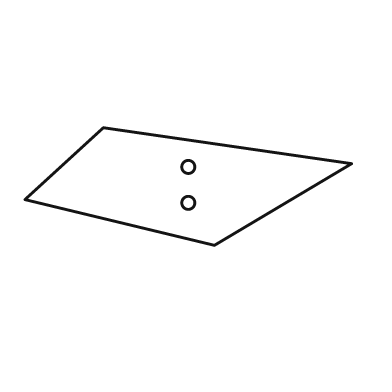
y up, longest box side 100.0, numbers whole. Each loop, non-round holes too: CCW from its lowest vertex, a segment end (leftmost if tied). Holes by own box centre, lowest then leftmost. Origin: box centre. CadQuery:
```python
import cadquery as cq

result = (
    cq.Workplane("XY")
    .moveTo(8.0, -18.0)
    .lineTo(50.0, 7.0)
    .lineTo(-26.0, 18.0)
    .lineTo(-50.0, -4.0)
    .close()
    .moveTo(0.0, -5.0)
    .circle(2.0)
    .moveTo(0.0, 6.0)
    .circle(2.0)
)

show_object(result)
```